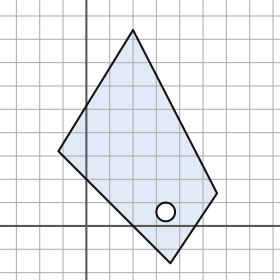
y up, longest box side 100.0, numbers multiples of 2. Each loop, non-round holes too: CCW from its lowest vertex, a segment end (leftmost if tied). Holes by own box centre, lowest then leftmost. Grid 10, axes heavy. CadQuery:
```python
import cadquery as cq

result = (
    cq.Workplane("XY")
    .moveTo(36.0, -16.0)
    .lineTo(56.0, 14.0)
    .lineTo(20.0, 84.0)
    .lineTo(-12.0, 32.0)
    .close()
    .moveTo(34.0, 6.0)
    .circle(4.0)
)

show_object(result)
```